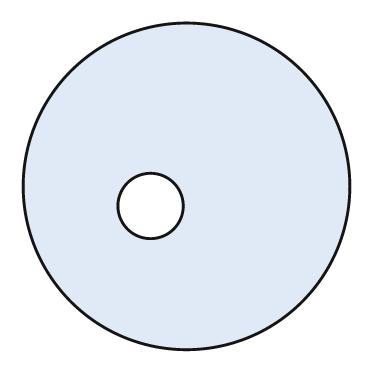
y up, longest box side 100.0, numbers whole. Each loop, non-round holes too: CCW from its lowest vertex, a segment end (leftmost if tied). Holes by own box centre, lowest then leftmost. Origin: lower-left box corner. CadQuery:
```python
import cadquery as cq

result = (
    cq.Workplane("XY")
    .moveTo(50.0, 50.0)
    .circle(50.0)
    .moveTo(39.0, 44.0)
    .circle(10.0)
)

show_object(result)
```